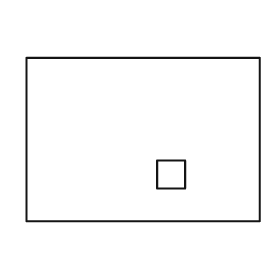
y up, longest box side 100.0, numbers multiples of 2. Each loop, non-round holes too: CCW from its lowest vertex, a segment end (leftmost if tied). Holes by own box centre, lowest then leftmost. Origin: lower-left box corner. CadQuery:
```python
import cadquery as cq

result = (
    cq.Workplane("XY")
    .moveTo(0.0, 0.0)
    .lineTo(100.0, 0.0)
    .lineTo(100.0, 70.0)
    .lineTo(0.0, 70.0)
    .close()
    .moveTo(56.0, 14.0)
    .lineTo(68.0, 14.0)
    .lineTo(68.0, 26.0)
    .lineTo(56.0, 26.0)
    .close()
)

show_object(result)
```